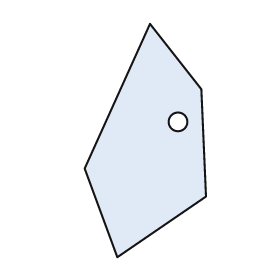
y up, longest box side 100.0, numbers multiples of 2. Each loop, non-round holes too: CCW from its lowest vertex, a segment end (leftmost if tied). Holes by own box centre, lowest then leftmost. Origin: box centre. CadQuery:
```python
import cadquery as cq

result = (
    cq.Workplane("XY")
    .moveTo(-12.0, -50.0)
    .lineTo(26.0, -24.0)
    .lineTo(24.0, 22.0)
    .lineTo(2.0, 50.0)
    .lineTo(-26.0, -12.0)
    .close()
    .moveTo(14.0, 8.0)
    .circle(4.0)
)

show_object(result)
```